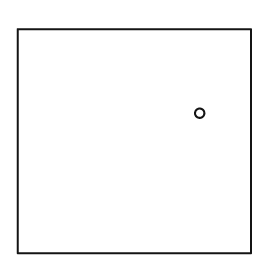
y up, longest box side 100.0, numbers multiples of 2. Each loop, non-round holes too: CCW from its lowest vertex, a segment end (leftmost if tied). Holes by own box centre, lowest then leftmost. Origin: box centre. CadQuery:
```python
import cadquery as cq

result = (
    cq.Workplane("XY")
    .moveTo(-50.0, -48.0)
    .lineTo(50.0, -48.0)
    .lineTo(50.0, 48.0)
    .lineTo(-50.0, 48.0)
    .close()
    .moveTo(28.0, 12.0)
    .circle(2.0)
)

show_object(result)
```